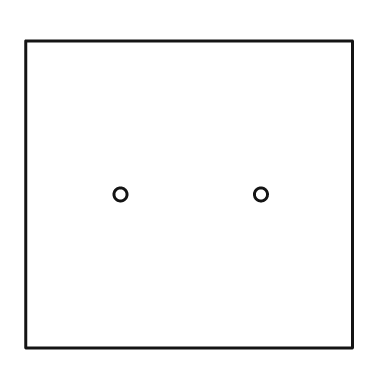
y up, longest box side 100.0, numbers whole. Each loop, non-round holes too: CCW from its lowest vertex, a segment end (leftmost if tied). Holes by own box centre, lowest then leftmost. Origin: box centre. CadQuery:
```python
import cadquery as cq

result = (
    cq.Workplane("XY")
    .moveTo(-50.0, -47.0)
    .lineTo(50.0, -47.0)
    .lineTo(50.0, 47.0)
    .lineTo(-50.0, 47.0)
    .close()
    .moveTo(-21.0, 0.0)
    .circle(2.0)
    .moveTo(22.0, 0.0)
    .circle(2.0)
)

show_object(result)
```